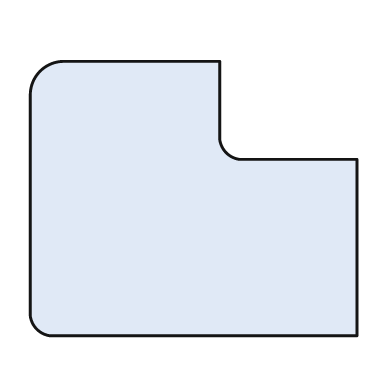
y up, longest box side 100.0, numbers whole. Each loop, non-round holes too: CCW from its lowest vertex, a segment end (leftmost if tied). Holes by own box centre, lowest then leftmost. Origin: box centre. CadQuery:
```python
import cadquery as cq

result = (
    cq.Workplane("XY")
    .moveTo(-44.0, -42.0)
    .lineTo(50.0, -42.0)
    .lineTo(50.0, 12.0)
    .lineTo(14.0, 12.0)
    .threePointArc((10.0, 14.0), (8.0, 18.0))
    .lineTo(8.0, 42.0)
    .lineTo(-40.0, 42.0)
    .threePointArc((-47.0, 39.0), (-50.0, 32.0))
    .lineTo(-50.0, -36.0)
    .threePointArc((-48.0, -40.0), (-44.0, -42.0))
    .close()
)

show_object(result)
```